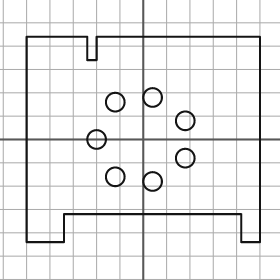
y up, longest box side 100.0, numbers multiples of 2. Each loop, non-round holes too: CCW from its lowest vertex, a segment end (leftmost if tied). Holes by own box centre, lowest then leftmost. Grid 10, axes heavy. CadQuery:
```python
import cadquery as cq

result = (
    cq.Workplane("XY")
    .moveTo(-50.0, -44.0)
    .lineTo(-34.0, -44.0)
    .lineTo(-34.0, -32.0)
    .lineTo(42.0, -32.0)
    .lineTo(42.0, -44.0)
    .lineTo(50.0, -44.0)
    .lineTo(50.0, 44.0)
    .lineTo(-20.0, 44.0)
    .lineTo(-20.0, 34.0)
    .lineTo(-24.0, 34.0)
    .lineTo(-24.0, 44.0)
    .lineTo(-50.0, 44.0)
    .close()
    .moveTo(4.0, -18.0)
    .circle(4.0)
    .moveTo(-12.0, -16.0)
    .circle(4.0)
    .moveTo(18.0, -8.0)
    .circle(4.0)
    .moveTo(-20.0, 0.0)
    .circle(4.0)
    .moveTo(18.0, 8.0)
    .circle(4.0)
    .moveTo(-12.0, 16.0)
    .circle(4.0)
    .moveTo(4.0, 18.0)
    .circle(4.0)
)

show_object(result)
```